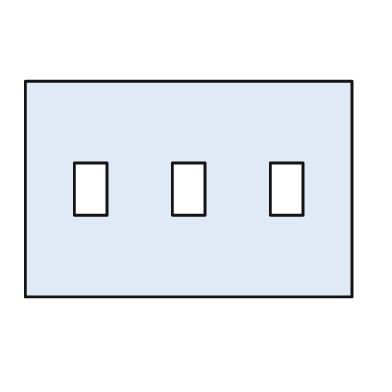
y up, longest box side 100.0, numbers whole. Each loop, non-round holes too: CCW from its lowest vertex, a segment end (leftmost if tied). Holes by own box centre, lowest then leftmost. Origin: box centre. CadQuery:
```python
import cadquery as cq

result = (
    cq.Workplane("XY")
    .moveTo(-50.0, -33.0)
    .lineTo(50.0, -33.0)
    .lineTo(50.0, 33.0)
    .lineTo(-50.0, 33.0)
    .close()
    .moveTo(-35.0, -8.0)
    .lineTo(-25.0, -8.0)
    .lineTo(-25.0, 8.0)
    .lineTo(-35.0, 8.0)
    .close()
    .moveTo(-5.0, -8.0)
    .lineTo(5.0, -8.0)
    .lineTo(5.0, 8.0)
    .lineTo(-5.0, 8.0)
    .close()
    .moveTo(25.0, -8.0)
    .lineTo(35.0, -8.0)
    .lineTo(35.0, 8.0)
    .lineTo(25.0, 8.0)
    .close()
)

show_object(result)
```